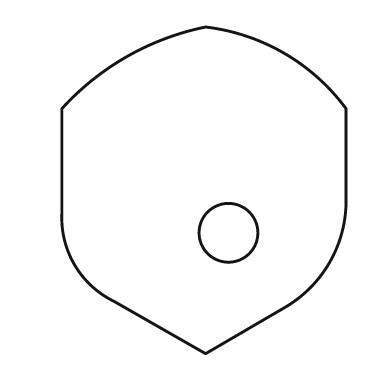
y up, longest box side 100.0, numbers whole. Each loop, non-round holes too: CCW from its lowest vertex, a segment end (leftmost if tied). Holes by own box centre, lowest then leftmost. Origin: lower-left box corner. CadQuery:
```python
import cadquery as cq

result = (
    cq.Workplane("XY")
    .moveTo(44.0, 0.0)
    .lineTo(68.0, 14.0)
    .threePointArc((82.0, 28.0), (87.0, 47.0))
    .lineTo(87.0, 75.0)
    .threePointArc((68.0, 92.0), (44.0, 100.0))
    .threePointArc((20.0, 91.0), (0.0, 75.0))
    .lineTo(0.0, 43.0)
    .threePointArc((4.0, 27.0), (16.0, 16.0))
    .close()
    .moveTo(51.0, 37.0)
    .circle(9.0)
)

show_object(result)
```